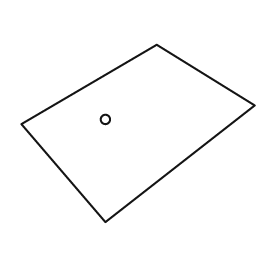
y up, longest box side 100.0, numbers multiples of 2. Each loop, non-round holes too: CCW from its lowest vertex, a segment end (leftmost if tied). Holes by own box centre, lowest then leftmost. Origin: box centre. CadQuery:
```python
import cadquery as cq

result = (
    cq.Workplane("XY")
    .moveTo(-14.0, -38.0)
    .lineTo(50.0, 12.0)
    .lineTo(8.0, 38.0)
    .lineTo(-50.0, 4.0)
    .close()
    .moveTo(-14.0, 6.0)
    .circle(2.0)
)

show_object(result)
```